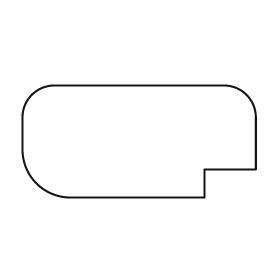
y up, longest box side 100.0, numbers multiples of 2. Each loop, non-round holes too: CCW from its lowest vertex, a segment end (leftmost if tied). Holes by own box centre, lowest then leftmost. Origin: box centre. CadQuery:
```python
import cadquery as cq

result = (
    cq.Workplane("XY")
    .moveTo(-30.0, -24.0)
    .lineTo(28.0, -24.0)
    .lineTo(28.0, -12.0)
    .lineTo(50.0, -12.0)
    .lineTo(50.0, 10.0)
    .threePointArc((46.0, 20.0), (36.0, 24.0))
    .lineTo(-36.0, 24.0)
    .threePointArc((-46.0, 20.0), (-50.0, 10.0))
    .lineTo(-50.0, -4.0)
    .threePointArc((-44.0, -18.0), (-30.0, -24.0))
    .close()
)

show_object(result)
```